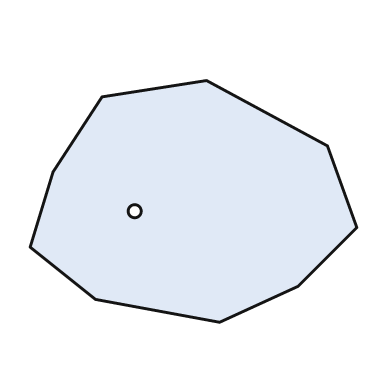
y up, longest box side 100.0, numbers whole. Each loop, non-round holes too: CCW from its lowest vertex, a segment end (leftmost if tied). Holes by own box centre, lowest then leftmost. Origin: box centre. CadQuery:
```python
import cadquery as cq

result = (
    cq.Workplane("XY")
    .moveTo(8.0, -37.0)
    .lineTo(32.0, -26.0)
    .lineTo(50.0, -8.0)
    .lineTo(41.0, 17.0)
    .lineTo(4.0, 37.0)
    .lineTo(-28.0, 32.0)
    .lineTo(-43.0, 9.0)
    .lineTo(-50.0, -14.0)
    .lineTo(-30.0, -30.0)
    .close()
    .moveTo(-18.0, -3.0)
    .circle(2.0)
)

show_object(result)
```